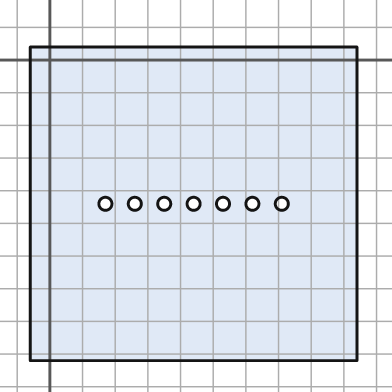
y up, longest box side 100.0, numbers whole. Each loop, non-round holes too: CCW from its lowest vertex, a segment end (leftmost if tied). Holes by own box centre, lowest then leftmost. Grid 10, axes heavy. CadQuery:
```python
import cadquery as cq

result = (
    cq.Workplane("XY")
    .moveTo(-6.0, -92.0)
    .lineTo(94.0, -92.0)
    .lineTo(94.0, 4.0)
    .lineTo(-6.0, 4.0)
    .close()
    .moveTo(17.0, -44.0)
    .circle(2.0)
    .moveTo(26.0, -44.0)
    .circle(2.0)
    .moveTo(35.0, -44.0)
    .circle(2.0)
    .moveTo(44.0, -44.0)
    .circle(2.0)
    .moveTo(53.0, -44.0)
    .circle(2.0)
    .moveTo(62.0, -44.0)
    .circle(2.0)
    .moveTo(71.0, -44.0)
    .circle(2.0)
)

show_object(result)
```